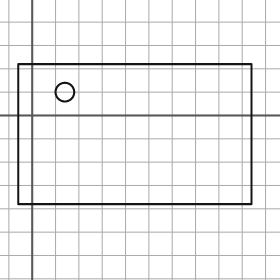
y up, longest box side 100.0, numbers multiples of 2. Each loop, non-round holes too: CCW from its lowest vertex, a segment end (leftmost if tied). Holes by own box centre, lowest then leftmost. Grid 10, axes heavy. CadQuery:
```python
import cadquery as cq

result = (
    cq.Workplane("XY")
    .moveTo(-6.0, -38.0)
    .lineTo(94.0, -38.0)
    .lineTo(94.0, 22.0)
    .lineTo(-6.0, 22.0)
    .close()
    .moveTo(14.0, 10.0)
    .circle(4.0)
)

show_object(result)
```